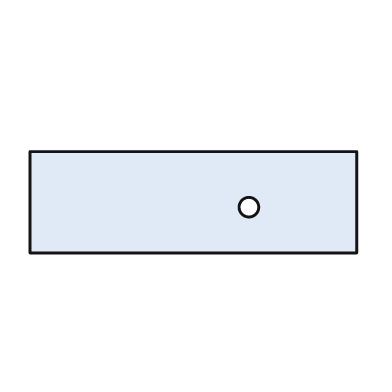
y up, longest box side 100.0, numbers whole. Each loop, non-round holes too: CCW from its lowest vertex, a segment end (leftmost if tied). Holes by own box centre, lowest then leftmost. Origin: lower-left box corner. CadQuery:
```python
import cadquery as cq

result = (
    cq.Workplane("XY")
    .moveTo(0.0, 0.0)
    .lineTo(100.0, 0.0)
    .lineTo(100.0, 31.0)
    .lineTo(0.0, 31.0)
    .close()
    .moveTo(67.0, 14.0)
    .circle(3.0)
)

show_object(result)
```